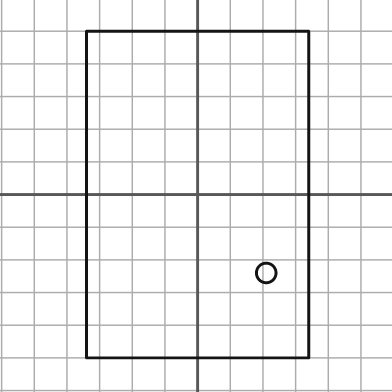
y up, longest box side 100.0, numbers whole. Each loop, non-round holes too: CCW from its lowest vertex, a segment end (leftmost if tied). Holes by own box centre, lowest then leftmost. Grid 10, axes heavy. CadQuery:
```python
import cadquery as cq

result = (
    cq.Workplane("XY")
    .moveTo(-34.0, -50.0)
    .lineTo(34.0, -50.0)
    .lineTo(34.0, 50.0)
    .lineTo(-34.0, 50.0)
    .close()
    .moveTo(21.0, -24.0)
    .circle(3.0)
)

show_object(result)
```